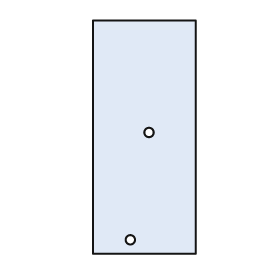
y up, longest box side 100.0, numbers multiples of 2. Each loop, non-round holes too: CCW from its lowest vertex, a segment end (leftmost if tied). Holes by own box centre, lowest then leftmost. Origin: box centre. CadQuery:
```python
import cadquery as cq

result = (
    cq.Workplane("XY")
    .moveTo(-22.0, -50.0)
    .lineTo(22.0, -50.0)
    .lineTo(22.0, 50.0)
    .lineTo(-22.0, 50.0)
    .close()
    .moveTo(-6.0, -44.0)
    .circle(2.0)
    .moveTo(2.0, 2.0)
    .circle(2.0)
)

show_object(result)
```